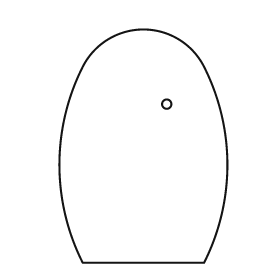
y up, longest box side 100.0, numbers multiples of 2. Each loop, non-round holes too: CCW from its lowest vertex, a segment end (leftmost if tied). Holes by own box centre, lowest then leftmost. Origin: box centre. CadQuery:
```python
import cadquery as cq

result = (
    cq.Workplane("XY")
    .moveTo(-26.0, -50.0)
    .lineTo(26.0, -50.0)
    .threePointArc((36.0, -8.0), (26.0, 34.0))
    .threePointArc((0.0, 50.0), (-26.0, 34.0))
    .threePointArc((-36.0, -8.0), (-26.0, -50.0))
    .close()
    .moveTo(10.0, 18.0)
    .circle(2.0)
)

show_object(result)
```